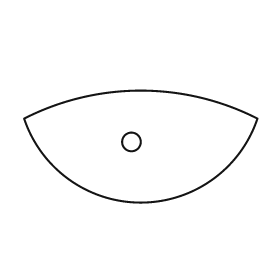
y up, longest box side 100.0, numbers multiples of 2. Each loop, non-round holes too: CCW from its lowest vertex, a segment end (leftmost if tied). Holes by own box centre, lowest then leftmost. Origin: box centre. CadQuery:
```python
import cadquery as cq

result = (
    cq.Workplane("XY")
    .moveTo(-50.0, 12.0)
    .threePointArc((0.0, -24.0), (50.0, 12.0))
    .threePointArc((0.0, 24.0), (-50.0, 12.0))
    .close()
    .moveTo(-4.0, 2.0)
    .circle(4.0)
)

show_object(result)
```